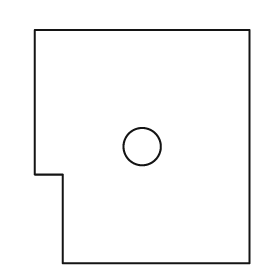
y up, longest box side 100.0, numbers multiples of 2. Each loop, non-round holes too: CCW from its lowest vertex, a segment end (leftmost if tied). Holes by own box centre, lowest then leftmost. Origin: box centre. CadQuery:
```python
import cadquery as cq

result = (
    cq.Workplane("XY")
    .moveTo(-34.0, -50.0)
    .lineTo(46.0, -50.0)
    .lineTo(46.0, 50.0)
    .lineTo(-46.0, 50.0)
    .lineTo(-46.0, -12.0)
    .lineTo(-34.0, -12.0)
    .close()
    .moveTo(0.0, 0.0)
    .circle(8.0)
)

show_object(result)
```